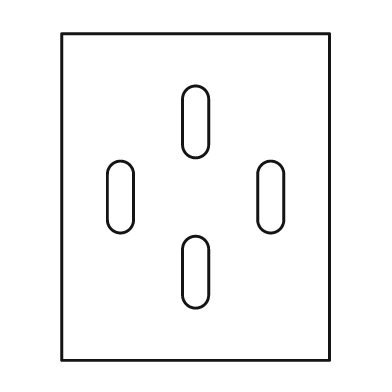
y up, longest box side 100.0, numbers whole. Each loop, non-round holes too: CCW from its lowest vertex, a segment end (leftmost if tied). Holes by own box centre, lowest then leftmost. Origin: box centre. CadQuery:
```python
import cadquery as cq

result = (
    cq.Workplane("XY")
    .moveTo(-41.0, -50.0)
    .lineTo(41.0, -50.0)
    .lineTo(41.0, 50.0)
    .lineTo(-41.0, 50.0)
    .close()
    .moveTo(-4.0, -30.0)
    .threePointArc((0.0, -34.0), (4.0, -30.0))
    .lineTo(4.0, -16.0)
    .threePointArc((0.0, -12.0), (-4.0, -16.0))
    .close()
    .moveTo(-27.0, -7.0)
    .threePointArc((-23.0, -11.0), (-19.0, -7.0))
    .lineTo(-19.0, 7.0)
    .threePointArc((-23.0, 11.0), (-27.0, 7.0))
    .close()
    .moveTo(19.0, -7.0)
    .threePointArc((23.0, -11.0), (27.0, -7.0))
    .lineTo(27.0, 7.0)
    .threePointArc((23.0, 11.0), (19.0, 7.0))
    .close()
    .moveTo(-4.0, 16.0)
    .threePointArc((0.0, 12.0), (4.0, 16.0))
    .lineTo(4.0, 30.0)
    .threePointArc((0.0, 34.0), (-4.0, 30.0))
    .close()
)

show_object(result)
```